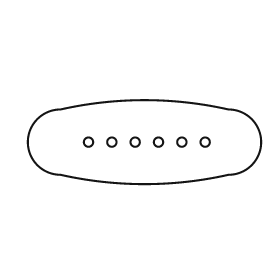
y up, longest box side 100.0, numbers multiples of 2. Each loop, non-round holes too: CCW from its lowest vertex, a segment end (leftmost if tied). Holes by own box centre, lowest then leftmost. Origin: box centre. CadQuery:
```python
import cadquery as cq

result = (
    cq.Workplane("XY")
    .moveTo(-36.0, -14.0)
    .threePointArc((0.0, -18.0), (36.0, -14.0))
    .threePointArc((50.0, 0.0), (36.0, 14.0))
    .threePointArc((0.0, 18.0), (-36.0, 14.0))
    .threePointArc((-50.0, 0.0), (-36.0, -14.0))
    .close()
    .moveTo(-24.0, 0.0)
    .circle(2.0)
    .moveTo(-14.0, 0.0)
    .circle(2.0)
    .moveTo(-4.0, 0.0)
    .circle(2.0)
    .moveTo(6.0, 0.0)
    .circle(2.0)
    .moveTo(16.0, 0.0)
    .circle(2.0)
    .moveTo(26.0, 0.0)
    .circle(2.0)
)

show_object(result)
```